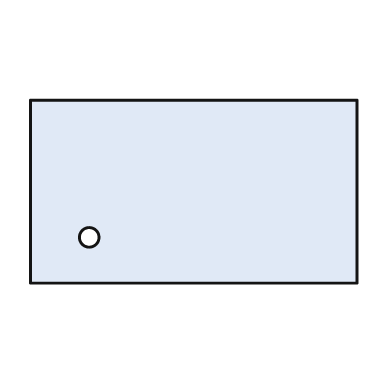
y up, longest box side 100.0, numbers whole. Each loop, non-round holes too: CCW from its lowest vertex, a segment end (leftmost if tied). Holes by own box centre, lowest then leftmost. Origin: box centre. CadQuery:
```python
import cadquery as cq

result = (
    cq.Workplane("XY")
    .moveTo(-50.0, -28.0)
    .lineTo(50.0, -28.0)
    .lineTo(50.0, 28.0)
    .lineTo(-50.0, 28.0)
    .close()
    .moveTo(-32.0, -14.0)
    .circle(3.0)
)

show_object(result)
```